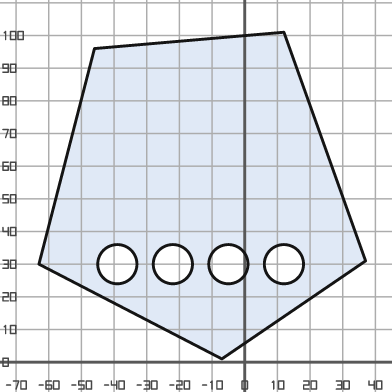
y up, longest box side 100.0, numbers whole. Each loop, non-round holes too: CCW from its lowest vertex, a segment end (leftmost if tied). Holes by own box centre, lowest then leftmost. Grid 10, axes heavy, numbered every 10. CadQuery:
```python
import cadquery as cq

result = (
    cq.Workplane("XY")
    .moveTo(-7.0, 1.0)
    .lineTo(37.0, 31.0)
    .lineTo(12.0, 101.0)
    .lineTo(-46.0, 96.0)
    .lineTo(-63.0, 30.0)
    .close()
    .moveTo(-39.0, 30.0)
    .circle(6.0)
    .moveTo(-22.0, 30.0)
    .circle(6.0)
    .moveTo(-5.0, 30.0)
    .circle(6.0)
    .moveTo(12.0, 30.0)
    .circle(6.0)
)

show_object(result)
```